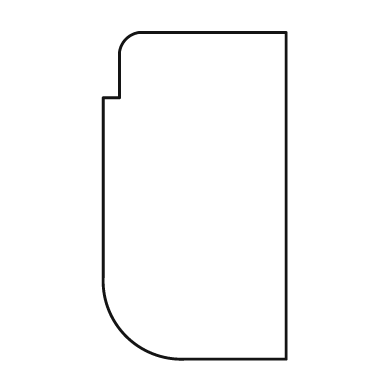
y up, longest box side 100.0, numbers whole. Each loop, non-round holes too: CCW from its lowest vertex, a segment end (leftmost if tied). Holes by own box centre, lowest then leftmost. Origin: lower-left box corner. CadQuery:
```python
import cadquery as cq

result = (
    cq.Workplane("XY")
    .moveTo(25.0, 0.0)
    .lineTo(56.0, 0.0)
    .lineTo(56.0, 100.0)
    .lineTo(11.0, 100.0)
    .threePointArc((7.0, 98.0), (5.0, 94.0))
    .lineTo(5.0, 80.0)
    .lineTo(0.0, 80.0)
    .lineTo(0.0, 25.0)
    .threePointArc((7.0, 7.0), (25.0, 0.0))
    .close()
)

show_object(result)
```